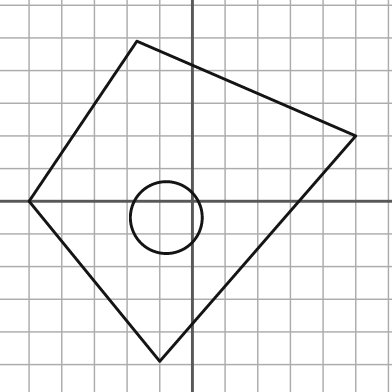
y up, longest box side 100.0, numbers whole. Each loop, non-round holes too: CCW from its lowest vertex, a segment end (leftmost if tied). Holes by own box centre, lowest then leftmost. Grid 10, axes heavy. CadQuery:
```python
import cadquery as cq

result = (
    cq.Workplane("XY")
    .moveTo(-10.0, -49.0)
    .lineTo(50.0, 20.0)
    .lineTo(-17.0, 49.0)
    .lineTo(-50.0, 0.0)
    .close()
    .moveTo(-8.0, -5.0)
    .circle(11.0)
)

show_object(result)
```